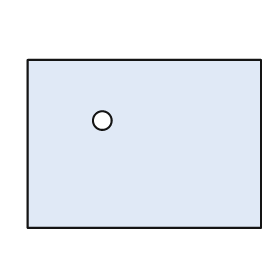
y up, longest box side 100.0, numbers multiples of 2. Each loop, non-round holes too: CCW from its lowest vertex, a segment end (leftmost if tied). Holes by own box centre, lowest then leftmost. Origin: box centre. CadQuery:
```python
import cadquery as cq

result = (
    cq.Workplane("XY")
    .moveTo(-50.0, -36.0)
    .lineTo(50.0, -36.0)
    .lineTo(50.0, 36.0)
    .lineTo(-50.0, 36.0)
    .close()
    .moveTo(-18.0, 10.0)
    .circle(4.0)
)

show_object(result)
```